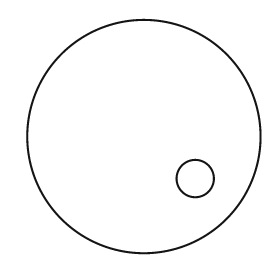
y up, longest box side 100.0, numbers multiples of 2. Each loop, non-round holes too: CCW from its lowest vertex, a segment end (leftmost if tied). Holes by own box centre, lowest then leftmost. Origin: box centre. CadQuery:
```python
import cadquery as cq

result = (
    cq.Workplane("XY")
    .moveTo(0.0, 0.0)
    .circle(50.0)
    .moveTo(22.0, -18.0)
    .circle(8.0)
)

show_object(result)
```